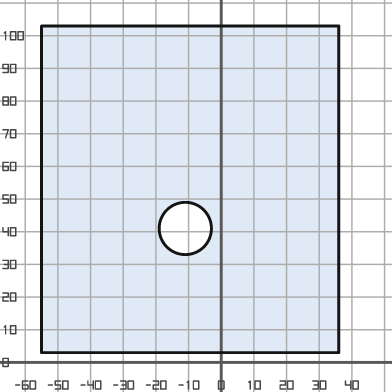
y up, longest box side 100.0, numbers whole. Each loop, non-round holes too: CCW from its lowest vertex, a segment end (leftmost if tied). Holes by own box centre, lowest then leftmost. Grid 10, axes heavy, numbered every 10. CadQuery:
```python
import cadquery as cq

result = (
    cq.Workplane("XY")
    .moveTo(-55.0, 3.0)
    .lineTo(36.0, 3.0)
    .lineTo(36.0, 103.0)
    .lineTo(-55.0, 103.0)
    .close()
    .moveTo(-11.0, 41.0)
    .circle(8.0)
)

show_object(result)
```